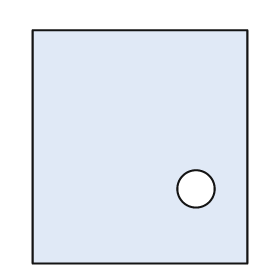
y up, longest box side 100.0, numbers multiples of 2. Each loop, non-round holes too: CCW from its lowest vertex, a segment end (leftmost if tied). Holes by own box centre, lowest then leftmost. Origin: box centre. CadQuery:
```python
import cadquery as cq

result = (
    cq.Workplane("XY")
    .moveTo(-46.0, -50.0)
    .lineTo(46.0, -50.0)
    .lineTo(46.0, 50.0)
    .lineTo(-46.0, 50.0)
    .close()
    .moveTo(24.0, -18.0)
    .circle(8.0)
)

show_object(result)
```